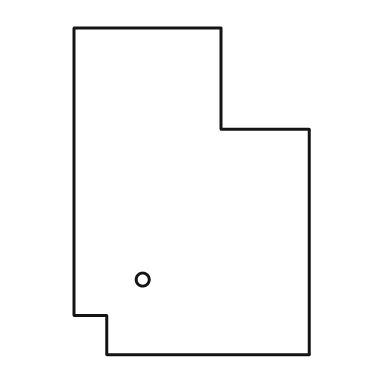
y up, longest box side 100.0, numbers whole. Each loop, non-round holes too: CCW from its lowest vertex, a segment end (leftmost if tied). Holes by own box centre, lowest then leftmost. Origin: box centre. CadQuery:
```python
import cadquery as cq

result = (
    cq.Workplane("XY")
    .moveTo(-26.0, -50.0)
    .lineTo(36.0, -50.0)
    .lineTo(36.0, 19.0)
    .lineTo(9.0, 19.0)
    .lineTo(9.0, 50.0)
    .lineTo(-36.0, 50.0)
    .lineTo(-36.0, -38.0)
    .lineTo(-26.0, -38.0)
    .close()
    .moveTo(-15.0, -27.0)
    .circle(2.0)
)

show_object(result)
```